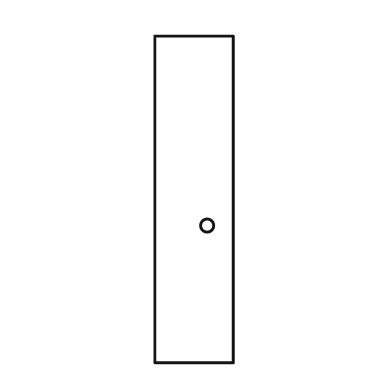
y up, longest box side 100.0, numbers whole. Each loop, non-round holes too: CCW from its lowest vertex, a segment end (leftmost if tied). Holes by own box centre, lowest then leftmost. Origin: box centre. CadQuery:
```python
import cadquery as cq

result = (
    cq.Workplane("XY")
    .moveTo(-12.0, -50.0)
    .lineTo(12.0, -50.0)
    .lineTo(12.0, 50.0)
    .lineTo(-12.0, 50.0)
    .close()
    .moveTo(4.0, -8.0)
    .circle(2.0)
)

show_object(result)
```